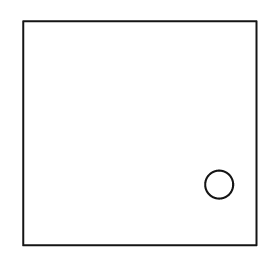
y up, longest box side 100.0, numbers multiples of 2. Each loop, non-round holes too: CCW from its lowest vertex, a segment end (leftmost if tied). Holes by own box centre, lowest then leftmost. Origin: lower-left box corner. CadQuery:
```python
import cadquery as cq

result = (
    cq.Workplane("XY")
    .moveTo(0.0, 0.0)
    .lineTo(100.0, 0.0)
    .lineTo(100.0, 96.0)
    .lineTo(0.0, 96.0)
    .close()
    .moveTo(84.0, 26.0)
    .circle(6.0)
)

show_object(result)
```